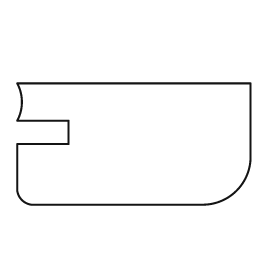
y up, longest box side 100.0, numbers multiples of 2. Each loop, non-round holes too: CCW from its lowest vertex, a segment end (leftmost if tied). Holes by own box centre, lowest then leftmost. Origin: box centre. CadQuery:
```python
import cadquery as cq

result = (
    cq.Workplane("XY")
    .moveTo(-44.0, -26.0)
    .lineTo(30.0, -26.0)
    .threePointArc((44.0, -20.0), (50.0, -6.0))
    .lineTo(50.0, 26.0)
    .lineTo(-50.0, 26.0)
    .threePointArc((-48.0, 18.0), (-50.0, 10.0))
    .lineTo(-28.0, 10.0)
    .lineTo(-28.0, 0.0)
    .lineTo(-50.0, 0.0)
    .lineTo(-50.0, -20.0)
    .threePointArc((-48.0, -24.0), (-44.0, -26.0))
    .close()
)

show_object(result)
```